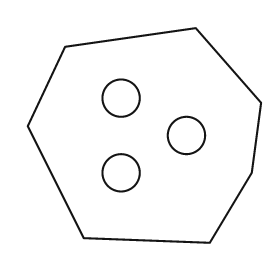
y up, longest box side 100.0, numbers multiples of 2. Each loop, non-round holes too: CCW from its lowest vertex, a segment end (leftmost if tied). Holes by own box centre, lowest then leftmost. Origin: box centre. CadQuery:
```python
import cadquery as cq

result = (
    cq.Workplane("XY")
    .moveTo(28.0, -46.0)
    .lineTo(46.0, -16.0)
    .lineTo(50.0, 14.0)
    .lineTo(22.0, 46.0)
    .lineTo(-34.0, 38.0)
    .lineTo(-50.0, 4.0)
    .lineTo(-26.0, -44.0)
    .close()
    .moveTo(-10.0, -16.0)
    .circle(8.0)
    .moveTo(18.0, 0.0)
    .circle(8.0)
    .moveTo(-10.0, 16.0)
    .circle(8.0)
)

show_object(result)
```